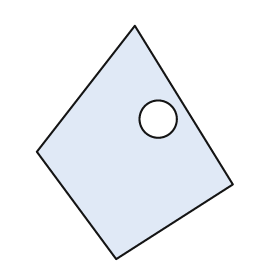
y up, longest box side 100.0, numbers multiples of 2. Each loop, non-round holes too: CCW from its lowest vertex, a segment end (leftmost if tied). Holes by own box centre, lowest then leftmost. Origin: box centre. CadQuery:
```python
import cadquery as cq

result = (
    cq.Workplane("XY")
    .moveTo(-8.0, -50.0)
    .lineTo(42.0, -18.0)
    .lineTo(0.0, 50.0)
    .lineTo(-42.0, -4.0)
    .close()
    .moveTo(10.0, 10.0)
    .circle(8.0)
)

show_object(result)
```